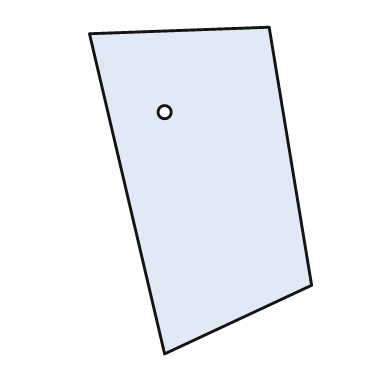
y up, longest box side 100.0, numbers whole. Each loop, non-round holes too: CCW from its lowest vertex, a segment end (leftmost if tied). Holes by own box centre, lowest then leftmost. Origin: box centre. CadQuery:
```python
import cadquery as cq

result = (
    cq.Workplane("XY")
    .moveTo(-11.0, -50.0)
    .lineTo(34.0, -29.0)
    .lineTo(21.0, 50.0)
    .lineTo(-34.0, 48.0)
    .close()
    .moveTo(-11.0, 24.0)
    .circle(2.0)
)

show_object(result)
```